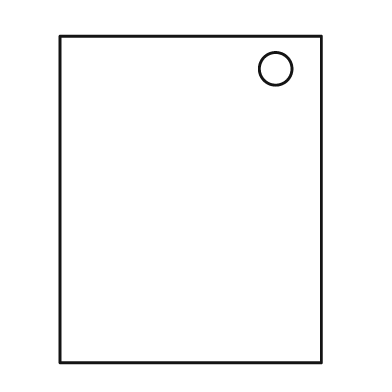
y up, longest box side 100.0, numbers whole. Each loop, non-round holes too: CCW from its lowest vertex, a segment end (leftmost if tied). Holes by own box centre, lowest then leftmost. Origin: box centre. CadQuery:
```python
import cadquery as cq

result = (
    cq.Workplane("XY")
    .moveTo(-40.0, -50.0)
    .lineTo(40.0, -50.0)
    .lineTo(40.0, 50.0)
    .lineTo(-40.0, 50.0)
    .close()
    .moveTo(26.0, 40.0)
    .circle(5.0)
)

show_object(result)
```